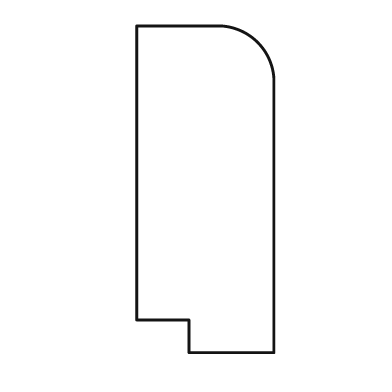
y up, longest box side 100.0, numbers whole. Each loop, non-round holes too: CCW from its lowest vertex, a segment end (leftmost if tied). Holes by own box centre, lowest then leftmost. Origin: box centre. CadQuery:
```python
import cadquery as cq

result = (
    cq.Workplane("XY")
    .moveTo(-5.0, -50.0)
    .lineTo(21.0, -50.0)
    .lineTo(21.0, 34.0)
    .threePointArc((16.0, 45.0), (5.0, 50.0))
    .lineTo(-21.0, 50.0)
    .lineTo(-21.0, -40.0)
    .lineTo(-5.0, -40.0)
    .close()
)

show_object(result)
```